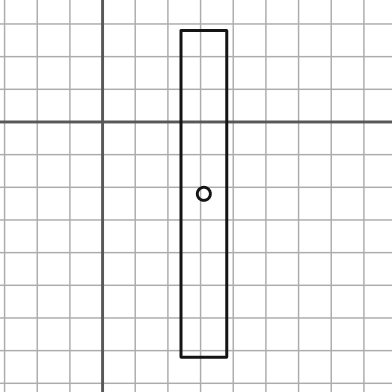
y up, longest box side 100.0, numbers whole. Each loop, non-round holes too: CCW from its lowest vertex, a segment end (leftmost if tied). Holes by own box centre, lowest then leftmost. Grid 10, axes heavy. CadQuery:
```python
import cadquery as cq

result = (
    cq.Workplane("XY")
    .moveTo(24.0, -72.0)
    .lineTo(38.0, -72.0)
    .lineTo(38.0, 28.0)
    .lineTo(24.0, 28.0)
    .close()
    .moveTo(31.0, -22.0)
    .circle(2.0)
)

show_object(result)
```